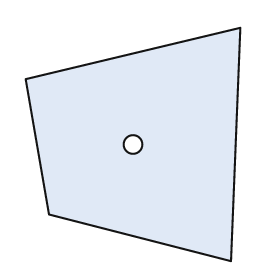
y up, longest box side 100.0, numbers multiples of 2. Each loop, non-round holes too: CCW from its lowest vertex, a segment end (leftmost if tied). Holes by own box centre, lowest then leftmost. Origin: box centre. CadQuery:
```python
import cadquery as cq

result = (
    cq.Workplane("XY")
    .moveTo(42.0, -50.0)
    .lineTo(46.0, 50.0)
    .lineTo(-46.0, 28.0)
    .lineTo(-36.0, -30.0)
    .close()
    .moveTo(0.0, 0.0)
    .circle(4.0)
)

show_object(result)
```